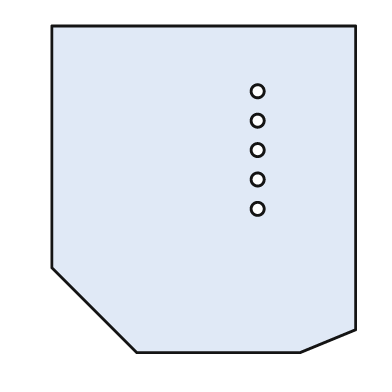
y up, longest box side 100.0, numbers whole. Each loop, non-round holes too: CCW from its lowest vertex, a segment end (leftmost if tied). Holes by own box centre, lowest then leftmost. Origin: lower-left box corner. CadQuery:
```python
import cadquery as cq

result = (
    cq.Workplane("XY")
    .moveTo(26.0, 0.0)
    .lineTo(76.0, 0.0)
    .lineTo(93.0, 7.0)
    .lineTo(93.0, 100.0)
    .lineTo(0.0, 100.0)
    .lineTo(0.0, 26.0)
    .close()
    .moveTo(63.0, 44.0)
    .circle(2.0)
    .moveTo(63.0, 53.0)
    .circle(2.0)
    .moveTo(63.0, 62.0)
    .circle(2.0)
    .moveTo(63.0, 71.0)
    .circle(2.0)
    .moveTo(63.0, 80.0)
    .circle(2.0)
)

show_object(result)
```